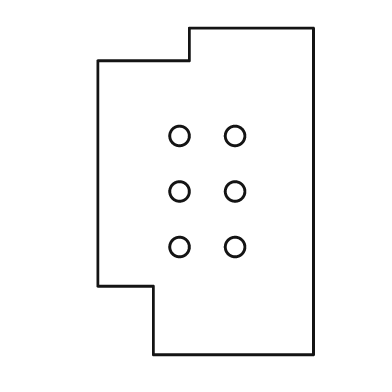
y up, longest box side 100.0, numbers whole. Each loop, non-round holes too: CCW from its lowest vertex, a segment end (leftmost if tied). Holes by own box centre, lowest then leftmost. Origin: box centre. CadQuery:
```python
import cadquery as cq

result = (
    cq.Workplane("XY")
    .moveTo(-16.0, -50.0)
    .lineTo(33.0, -50.0)
    .lineTo(33.0, 50.0)
    .lineTo(-5.0, 50.0)
    .lineTo(-5.0, 40.0)
    .lineTo(-33.0, 40.0)
    .lineTo(-33.0, -29.0)
    .lineTo(-16.0, -29.0)
    .close()
    .moveTo(-8.0, -17.0)
    .circle(3.0)
    .moveTo(9.0, -17.0)
    .circle(3.0)
    .moveTo(-8.0, 0.0)
    .circle(3.0)
    .moveTo(9.0, 0.0)
    .circle(3.0)
    .moveTo(-8.0, 17.0)
    .circle(3.0)
    .moveTo(9.0, 17.0)
    .circle(3.0)
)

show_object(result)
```